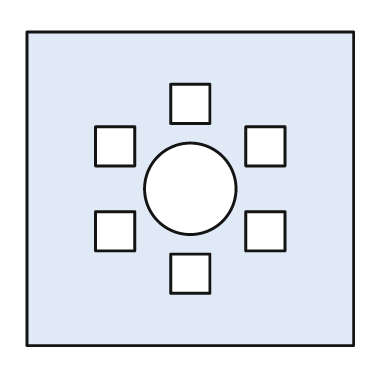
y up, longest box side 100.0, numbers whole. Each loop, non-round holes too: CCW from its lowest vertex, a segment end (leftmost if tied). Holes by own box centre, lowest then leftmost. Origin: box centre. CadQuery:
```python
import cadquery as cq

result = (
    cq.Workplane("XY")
    .moveTo(-50.0, -48.0)
    .lineTo(50.0, -48.0)
    .lineTo(50.0, 48.0)
    .lineTo(-50.0, 48.0)
    .close()
    .moveTo(-6.0, -32.0)
    .lineTo(6.0, -32.0)
    .lineTo(6.0, -20.0)
    .lineTo(-6.0, -20.0)
    .close()
    .moveTo(-29.0, -19.0)
    .lineTo(-17.0, -19.0)
    .lineTo(-17.0, -7.0)
    .lineTo(-29.0, -7.0)
    .close()
    .moveTo(17.0, -19.0)
    .lineTo(29.0, -19.0)
    .lineTo(29.0, -7.0)
    .lineTo(17.0, -7.0)
    .close()
    .moveTo(0.0, 0.0)
    .circle(14.0)
    .moveTo(-29.0, 7.0)
    .lineTo(-17.0, 7.0)
    .lineTo(-17.0, 19.0)
    .lineTo(-29.0, 19.0)
    .close()
    .moveTo(17.0, 7.0)
    .lineTo(29.0, 7.0)
    .lineTo(29.0, 19.0)
    .lineTo(17.0, 19.0)
    .close()
    .moveTo(-6.0, 20.0)
    .lineTo(6.0, 20.0)
    .lineTo(6.0, 32.0)
    .lineTo(-6.0, 32.0)
    .close()
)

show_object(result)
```